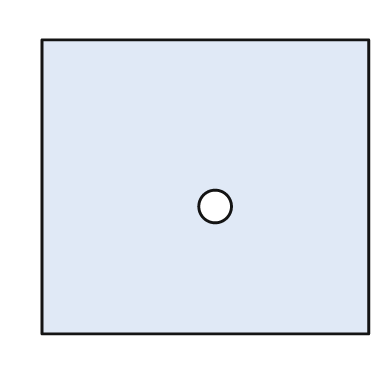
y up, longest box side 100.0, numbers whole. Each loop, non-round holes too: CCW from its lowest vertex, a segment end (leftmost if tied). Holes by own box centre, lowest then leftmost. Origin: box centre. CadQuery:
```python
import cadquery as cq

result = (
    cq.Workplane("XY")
    .moveTo(-50.0, -45.0)
    .lineTo(50.0, -45.0)
    .lineTo(50.0, 45.0)
    .lineTo(-50.0, 45.0)
    .close()
    .moveTo(3.0, -6.0)
    .circle(5.0)
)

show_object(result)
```